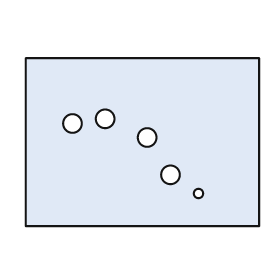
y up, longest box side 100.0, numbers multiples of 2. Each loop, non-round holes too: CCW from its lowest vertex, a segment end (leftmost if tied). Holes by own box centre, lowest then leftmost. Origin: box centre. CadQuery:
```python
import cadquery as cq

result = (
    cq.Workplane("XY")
    .moveTo(-50.0, -36.0)
    .lineTo(50.0, -36.0)
    .lineTo(50.0, 36.0)
    .lineTo(-50.0, 36.0)
    .close()
    .moveTo(24.0, -22.0)
    .circle(2.0)
    .moveTo(12.0, -14.0)
    .circle(4.0)
    .moveTo(2.0, 2.0)
    .circle(4.0)
    .moveTo(-30.0, 8.0)
    .circle(4.0)
    .moveTo(-16.0, 10.0)
    .circle(4.0)
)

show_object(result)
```